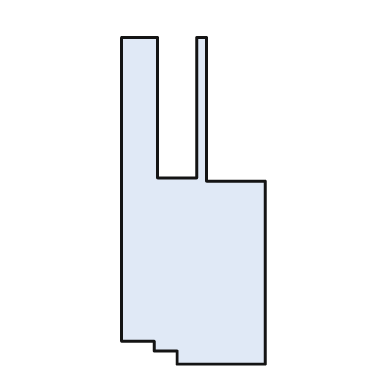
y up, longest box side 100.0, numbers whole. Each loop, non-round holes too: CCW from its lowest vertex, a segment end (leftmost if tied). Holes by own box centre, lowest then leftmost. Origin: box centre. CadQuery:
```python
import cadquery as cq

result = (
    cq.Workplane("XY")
    .moveTo(-5.0, -50.0)
    .lineTo(22.0, -50.0)
    .lineTo(22.0, 6.0)
    .lineTo(4.0, 6.0)
    .lineTo(4.0, 50.0)
    .lineTo(1.0, 50.0)
    .lineTo(1.0, 7.0)
    .lineTo(-11.0, 7.0)
    .lineTo(-11.0, 50.0)
    .lineTo(-22.0, 50.0)
    .lineTo(-22.0, -43.0)
    .lineTo(-12.0, -43.0)
    .lineTo(-12.0, -46.0)
    .lineTo(-5.0, -46.0)
    .close()
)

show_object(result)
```